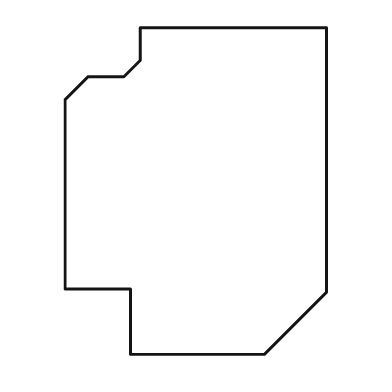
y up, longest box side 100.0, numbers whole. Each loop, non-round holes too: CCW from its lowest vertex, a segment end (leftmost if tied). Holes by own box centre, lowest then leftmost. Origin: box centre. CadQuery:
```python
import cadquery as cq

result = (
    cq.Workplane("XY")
    .moveTo(-20.0, -50.0)
    .lineTo(21.0, -50.0)
    .lineTo(40.0, -31.0)
    .lineTo(40.0, 50.0)
    .lineTo(-17.0, 50.0)
    .lineTo(-17.0, 40.0)
    .lineTo(-22.0, 35.0)
    .lineTo(-33.0, 35.0)
    .lineTo(-40.0, 28.0)
    .lineTo(-40.0, -30.0)
    .lineTo(-20.0, -30.0)
    .close()
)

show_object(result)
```